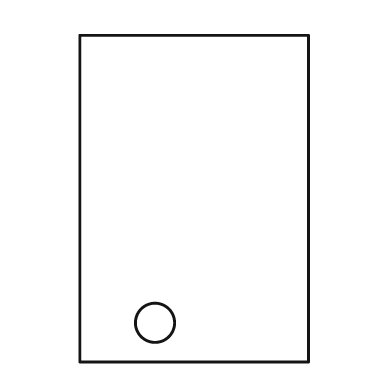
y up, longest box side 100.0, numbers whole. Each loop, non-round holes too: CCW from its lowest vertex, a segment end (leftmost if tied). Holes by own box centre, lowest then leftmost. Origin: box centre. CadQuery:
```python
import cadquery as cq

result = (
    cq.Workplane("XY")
    .moveTo(-35.0, -50.0)
    .lineTo(35.0, -50.0)
    .lineTo(35.0, 50.0)
    .lineTo(-35.0, 50.0)
    .close()
    .moveTo(-12.0, -38.0)
    .circle(6.0)
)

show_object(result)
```